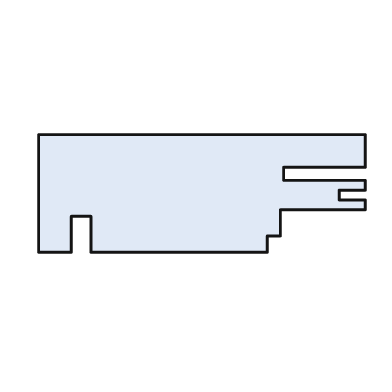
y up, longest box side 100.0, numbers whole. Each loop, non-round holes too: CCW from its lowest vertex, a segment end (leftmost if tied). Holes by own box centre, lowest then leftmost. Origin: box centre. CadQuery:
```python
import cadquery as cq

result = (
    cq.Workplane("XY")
    .moveTo(-50.0, -18.0)
    .lineTo(-40.0, -18.0)
    .lineTo(-40.0, -7.0)
    .lineTo(-34.0, -7.0)
    .lineTo(-34.0, -18.0)
    .lineTo(20.0, -18.0)
    .lineTo(20.0, -13.0)
    .lineTo(24.0, -13.0)
    .lineTo(24.0, -5.0)
    .lineTo(50.0, -5.0)
    .lineTo(50.0, -2.0)
    .lineTo(42.0, -2.0)
    .lineTo(42.0, 1.0)
    .lineTo(50.0, 1.0)
    .lineTo(50.0, 4.0)
    .lineTo(25.0, 4.0)
    .lineTo(25.0, 8.0)
    .lineTo(50.0, 8.0)
    .lineTo(50.0, 18.0)
    .lineTo(-50.0, 18.0)
    .close()
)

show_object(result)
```